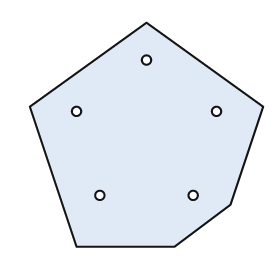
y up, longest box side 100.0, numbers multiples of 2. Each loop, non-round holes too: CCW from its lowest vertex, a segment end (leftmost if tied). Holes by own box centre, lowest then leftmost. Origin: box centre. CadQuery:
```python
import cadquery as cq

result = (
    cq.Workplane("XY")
    .moveTo(-30.0, -48.0)
    .lineTo(12.0, -48.0)
    .lineTo(36.0, -30.0)
    .lineTo(50.0, 12.0)
    .lineTo(0.0, 48.0)
    .lineTo(-50.0, 12.0)
    .close()
    .moveTo(-20.0, -26.0)
    .circle(2.0)
    .moveTo(20.0, -26.0)
    .circle(2.0)
    .moveTo(-30.0, 10.0)
    .circle(2.0)
    .moveTo(30.0, 10.0)
    .circle(2.0)
    .moveTo(0.0, 32.0)
    .circle(2.0)
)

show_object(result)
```